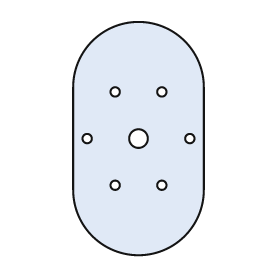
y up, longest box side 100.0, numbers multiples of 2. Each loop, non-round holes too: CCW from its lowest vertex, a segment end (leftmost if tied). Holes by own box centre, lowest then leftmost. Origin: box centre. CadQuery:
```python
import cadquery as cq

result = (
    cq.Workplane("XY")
    .moveTo(-28.0, -22.0)
    .threePointArc((0.0, -50.0), (28.0, -22.0))
    .lineTo(28.0, 22.0)
    .threePointArc((0.0, 50.0), (-28.0, 22.0))
    .close()
    .moveTo(-10.0, -20.0)
    .circle(2.0)
    .moveTo(10.0, -20.0)
    .circle(2.0)
    .moveTo(-22.0, 0.0)
    .circle(2.0)
    .moveTo(0.0, 0.0)
    .circle(4.0)
    .moveTo(22.0, 0.0)
    .circle(2.0)
    .moveTo(-10.0, 20.0)
    .circle(2.0)
    .moveTo(10.0, 20.0)
    .circle(2.0)
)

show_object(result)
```